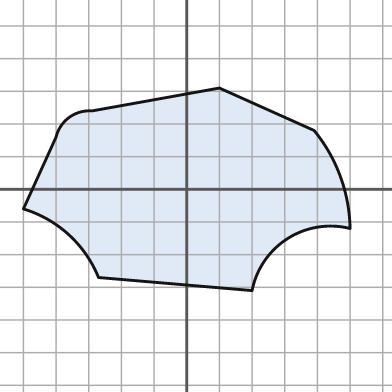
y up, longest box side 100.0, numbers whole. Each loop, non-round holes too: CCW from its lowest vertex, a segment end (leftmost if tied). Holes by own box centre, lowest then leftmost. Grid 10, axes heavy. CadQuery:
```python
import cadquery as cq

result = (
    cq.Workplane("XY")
    .moveTo(20.0, -31.0)
    .threePointArc((31.0, -15.0), (50.0, -12.0))
    .threePointArc((47.0, 4.0), (39.0, 18.0))
    .lineTo(10.0, 31.0)
    .lineTo(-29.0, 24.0)
    .threePointArc((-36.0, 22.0), (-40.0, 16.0))
    .lineTo(-50.0, -6.0)
    .threePointArc((-36.0, -14.0), (-27.0, -27.0))
    .close()
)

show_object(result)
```